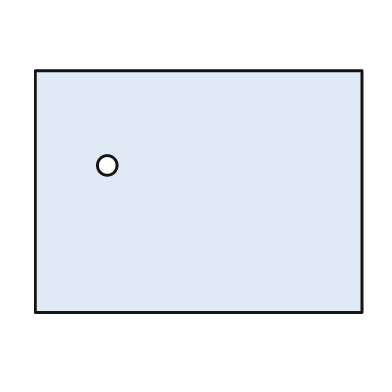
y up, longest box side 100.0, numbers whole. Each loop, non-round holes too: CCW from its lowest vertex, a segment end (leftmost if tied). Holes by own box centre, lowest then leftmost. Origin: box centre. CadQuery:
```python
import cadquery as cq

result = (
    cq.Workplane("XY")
    .moveTo(-50.0, -37.0)
    .lineTo(50.0, -37.0)
    .lineTo(50.0, 37.0)
    .lineTo(-50.0, 37.0)
    .close()
    .moveTo(-28.0, 8.0)
    .circle(3.0)
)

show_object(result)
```